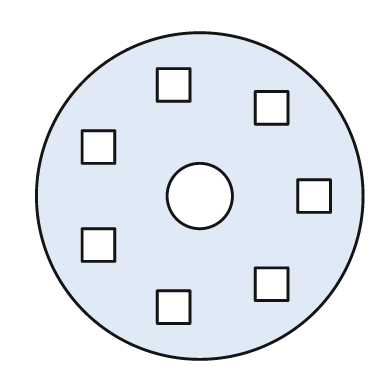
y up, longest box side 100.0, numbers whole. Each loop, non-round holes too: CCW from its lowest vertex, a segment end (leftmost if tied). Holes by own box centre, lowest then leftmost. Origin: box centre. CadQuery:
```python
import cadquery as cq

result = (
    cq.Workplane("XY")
    .moveTo(0.0, 0.0)
    .circle(50.0)
    .moveTo(-13.0, -39.0)
    .lineTo(-3.0, -39.0)
    .lineTo(-3.0, -29.0)
    .lineTo(-13.0, -29.0)
    .close()
    .moveTo(17.0, -32.0)
    .lineTo(27.0, -32.0)
    .lineTo(27.0, -22.0)
    .lineTo(17.0, -22.0)
    .close()
    .moveTo(-36.0, -20.0)
    .lineTo(-26.0, -20.0)
    .lineTo(-26.0, -10.0)
    .lineTo(-36.0, -10.0)
    .close()
    .moveTo(0.0, 0.0)
    .circle(10.0)
    .moveTo(30.0, -5.0)
    .lineTo(40.0, -5.0)
    .lineTo(40.0, 5.0)
    .lineTo(30.0, 5.0)
    .close()
    .moveTo(-36.0, 10.0)
    .lineTo(-26.0, 10.0)
    .lineTo(-26.0, 20.0)
    .lineTo(-36.0, 20.0)
    .close()
    .moveTo(17.0, 22.0)
    .lineTo(27.0, 22.0)
    .lineTo(27.0, 32.0)
    .lineTo(17.0, 32.0)
    .close()
    .moveTo(-13.0, 29.0)
    .lineTo(-3.0, 29.0)
    .lineTo(-3.0, 39.0)
    .lineTo(-13.0, 39.0)
    .close()
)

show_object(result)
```